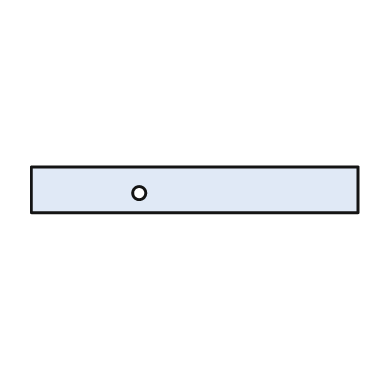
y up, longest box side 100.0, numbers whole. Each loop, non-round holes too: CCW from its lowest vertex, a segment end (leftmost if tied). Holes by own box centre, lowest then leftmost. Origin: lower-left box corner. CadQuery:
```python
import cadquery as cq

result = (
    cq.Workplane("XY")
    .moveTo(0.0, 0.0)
    .lineTo(100.0, 0.0)
    .lineTo(100.0, 14.0)
    .lineTo(0.0, 14.0)
    .close()
    .moveTo(33.0, 6.0)
    .circle(2.0)
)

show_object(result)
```